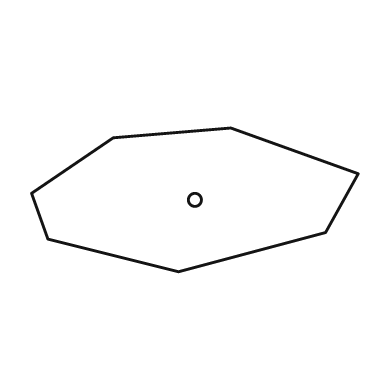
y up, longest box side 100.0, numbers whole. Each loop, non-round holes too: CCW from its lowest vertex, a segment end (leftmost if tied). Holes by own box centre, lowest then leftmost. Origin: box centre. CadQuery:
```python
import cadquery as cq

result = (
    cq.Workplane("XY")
    .moveTo(-5.0, -22.0)
    .lineTo(40.0, -10.0)
    .lineTo(50.0, 8.0)
    .lineTo(11.0, 22.0)
    .lineTo(-25.0, 19.0)
    .lineTo(-50.0, 2.0)
    .lineTo(-45.0, -12.0)
    .close()
    .moveTo(0.0, 0.0)
    .circle(2.0)
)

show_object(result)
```